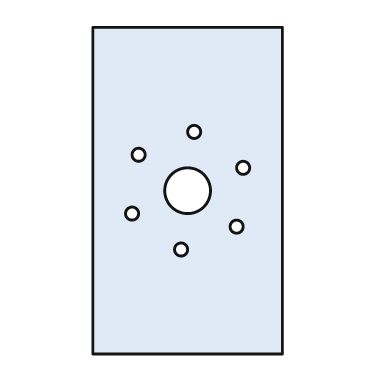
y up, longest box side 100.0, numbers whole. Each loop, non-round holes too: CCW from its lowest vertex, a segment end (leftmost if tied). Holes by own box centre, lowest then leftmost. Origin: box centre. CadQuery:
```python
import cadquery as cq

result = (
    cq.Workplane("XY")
    .moveTo(-29.0, -50.0)
    .lineTo(29.0, -50.0)
    .lineTo(29.0, 50.0)
    .lineTo(-29.0, 50.0)
    .close()
    .moveTo(-2.0, -18.0)
    .circle(2.0)
    .moveTo(15.0, -11.0)
    .circle(2.0)
    .moveTo(-17.0, -7.0)
    .circle(2.0)
    .moveTo(0.0, 0.0)
    .circle(7.0)
    .moveTo(17.0, 7.0)
    .circle(2.0)
    .moveTo(-15.0, 11.0)
    .circle(2.0)
    .moveTo(2.0, 18.0)
    .circle(2.0)
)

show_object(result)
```